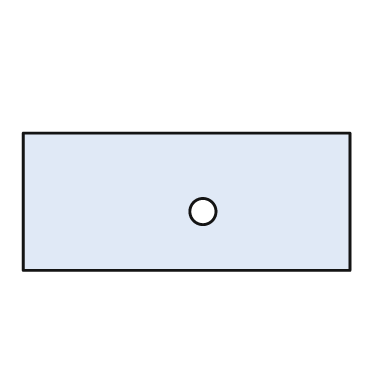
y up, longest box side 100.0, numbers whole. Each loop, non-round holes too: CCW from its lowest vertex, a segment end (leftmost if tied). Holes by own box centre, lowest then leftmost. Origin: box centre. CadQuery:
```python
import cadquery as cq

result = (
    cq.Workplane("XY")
    .moveTo(-50.0, -21.0)
    .lineTo(50.0, -21.0)
    .lineTo(50.0, 21.0)
    .lineTo(-50.0, 21.0)
    .close()
    .moveTo(5.0, -3.0)
    .circle(4.0)
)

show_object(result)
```